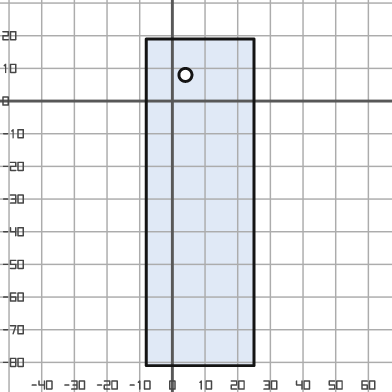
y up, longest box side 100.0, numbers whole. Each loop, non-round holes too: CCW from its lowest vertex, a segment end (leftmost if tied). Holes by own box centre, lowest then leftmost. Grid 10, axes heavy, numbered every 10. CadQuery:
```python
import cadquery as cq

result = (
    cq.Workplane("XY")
    .moveTo(-8.0, -81.0)
    .lineTo(25.0, -81.0)
    .lineTo(25.0, 19.0)
    .lineTo(-8.0, 19.0)
    .close()
    .moveTo(4.0, 8.0)
    .circle(2.0)
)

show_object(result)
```